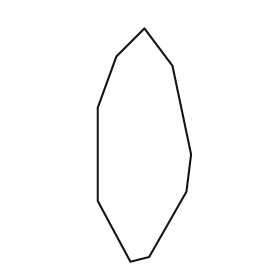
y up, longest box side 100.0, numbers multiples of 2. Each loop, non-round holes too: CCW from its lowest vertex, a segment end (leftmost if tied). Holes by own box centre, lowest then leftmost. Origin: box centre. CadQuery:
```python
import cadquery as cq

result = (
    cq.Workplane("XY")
    .moveTo(-6.0, -50.0)
    .lineTo(2.0, -48.0)
    .lineTo(18.0, -20.0)
    .lineTo(20.0, -4.0)
    .lineTo(12.0, 34.0)
    .lineTo(0.0, 50.0)
    .lineTo(-12.0, 38.0)
    .lineTo(-20.0, 16.0)
    .lineTo(-20.0, -24.0)
    .close()
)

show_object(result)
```